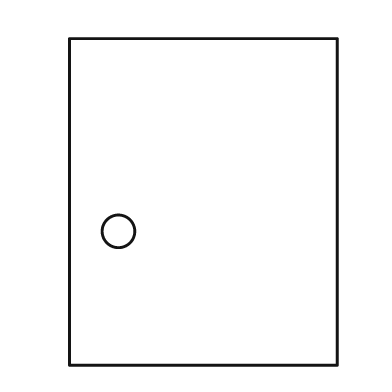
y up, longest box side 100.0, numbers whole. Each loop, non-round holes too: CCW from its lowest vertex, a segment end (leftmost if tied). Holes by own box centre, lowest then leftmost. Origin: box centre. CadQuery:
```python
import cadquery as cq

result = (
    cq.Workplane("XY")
    .moveTo(-41.0, -50.0)
    .lineTo(41.0, -50.0)
    .lineTo(41.0, 50.0)
    .lineTo(-41.0, 50.0)
    .close()
    .moveTo(-26.0, -9.0)
    .circle(5.0)
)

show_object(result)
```